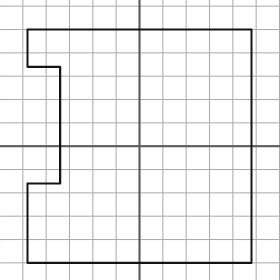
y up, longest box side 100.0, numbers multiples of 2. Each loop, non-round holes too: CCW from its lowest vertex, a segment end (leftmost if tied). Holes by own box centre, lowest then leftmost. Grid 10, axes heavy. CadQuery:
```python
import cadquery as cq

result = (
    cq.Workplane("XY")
    .moveTo(-48.0, -50.0)
    .lineTo(48.0, -50.0)
    .lineTo(48.0, 50.0)
    .lineTo(-48.0, 50.0)
    .lineTo(-48.0, 34.0)
    .lineTo(-34.0, 34.0)
    .lineTo(-34.0, -16.0)
    .lineTo(-48.0, -16.0)
    .close()
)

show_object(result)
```